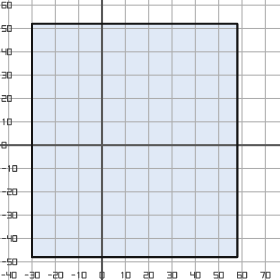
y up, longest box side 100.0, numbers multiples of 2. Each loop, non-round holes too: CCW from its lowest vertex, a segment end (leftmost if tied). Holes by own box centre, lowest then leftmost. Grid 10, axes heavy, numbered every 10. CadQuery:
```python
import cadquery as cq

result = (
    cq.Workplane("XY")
    .moveTo(-30.0, -48.0)
    .lineTo(58.0, -48.0)
    .lineTo(58.0, 52.0)
    .lineTo(-30.0, 52.0)
    .close()
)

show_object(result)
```